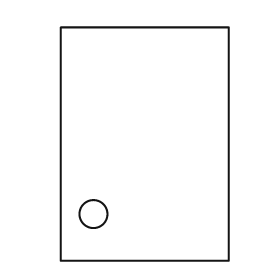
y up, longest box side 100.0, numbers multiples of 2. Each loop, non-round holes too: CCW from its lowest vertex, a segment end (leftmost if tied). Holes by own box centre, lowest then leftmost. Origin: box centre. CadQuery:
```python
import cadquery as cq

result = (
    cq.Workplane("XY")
    .moveTo(-36.0, -50.0)
    .lineTo(36.0, -50.0)
    .lineTo(36.0, 50.0)
    .lineTo(-36.0, 50.0)
    .close()
    .moveTo(-22.0, -30.0)
    .circle(6.0)
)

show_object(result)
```